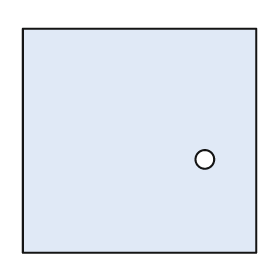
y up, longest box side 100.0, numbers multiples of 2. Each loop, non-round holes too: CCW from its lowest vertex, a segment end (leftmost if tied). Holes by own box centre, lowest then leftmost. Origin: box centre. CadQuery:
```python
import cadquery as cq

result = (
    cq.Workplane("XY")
    .moveTo(-50.0, -48.0)
    .lineTo(50.0, -48.0)
    .lineTo(50.0, 48.0)
    .lineTo(-50.0, 48.0)
    .close()
    .moveTo(28.0, -8.0)
    .circle(4.0)
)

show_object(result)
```